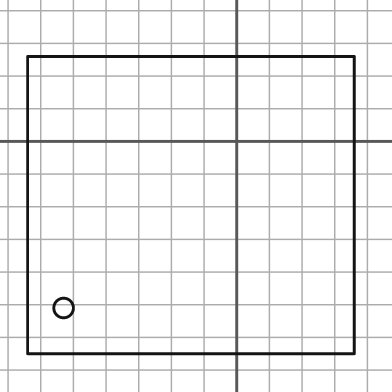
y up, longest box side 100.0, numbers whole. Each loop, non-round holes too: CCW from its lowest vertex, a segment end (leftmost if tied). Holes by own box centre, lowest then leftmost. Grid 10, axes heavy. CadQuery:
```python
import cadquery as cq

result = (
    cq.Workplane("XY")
    .moveTo(-64.0, -65.0)
    .lineTo(36.0, -65.0)
    .lineTo(36.0, 26.0)
    .lineTo(-64.0, 26.0)
    .close()
    .moveTo(-53.0, -51.0)
    .circle(3.0)
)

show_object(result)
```